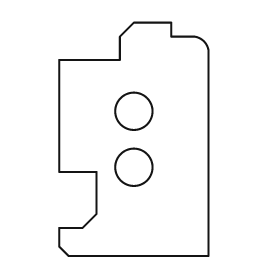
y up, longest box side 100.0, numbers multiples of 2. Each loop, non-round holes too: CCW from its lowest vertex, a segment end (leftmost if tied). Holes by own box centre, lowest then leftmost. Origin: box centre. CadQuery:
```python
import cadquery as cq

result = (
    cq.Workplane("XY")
    .moveTo(-28.0, -50.0)
    .lineTo(32.0, -50.0)
    .lineTo(32.0, 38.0)
    .threePointArc((30.0, 42.0), (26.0, 44.0))
    .lineTo(16.0, 44.0)
    .lineTo(16.0, 50.0)
    .lineTo(0.0, 50.0)
    .lineTo(-6.0, 44.0)
    .lineTo(-6.0, 34.0)
    .lineTo(-32.0, 34.0)
    .lineTo(-32.0, -14.0)
    .lineTo(-16.0, -14.0)
    .lineTo(-16.0, -32.0)
    .lineTo(-22.0, -38.0)
    .lineTo(-32.0, -38.0)
    .lineTo(-32.0, -46.0)
    .close()
    .moveTo(0.0, -12.0)
    .circle(8.0)
    .moveTo(0.0, 12.0)
    .circle(8.0)
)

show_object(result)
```